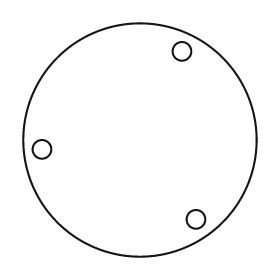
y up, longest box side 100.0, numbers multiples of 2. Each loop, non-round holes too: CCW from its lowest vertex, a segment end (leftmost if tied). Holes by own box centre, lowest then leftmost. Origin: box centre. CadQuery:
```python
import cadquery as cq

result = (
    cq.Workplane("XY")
    .moveTo(0.0, 0.0)
    .circle(50.0)
    .moveTo(24.0, -34.0)
    .circle(4.0)
    .moveTo(-42.0, -4.0)
    .circle(4.0)
    .moveTo(18.0, 38.0)
    .circle(4.0)
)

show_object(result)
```